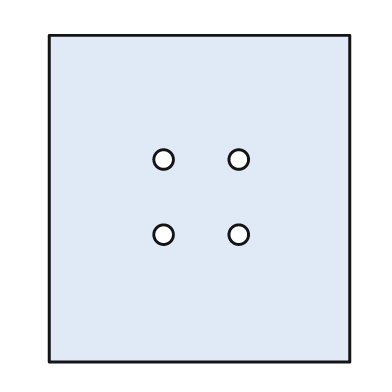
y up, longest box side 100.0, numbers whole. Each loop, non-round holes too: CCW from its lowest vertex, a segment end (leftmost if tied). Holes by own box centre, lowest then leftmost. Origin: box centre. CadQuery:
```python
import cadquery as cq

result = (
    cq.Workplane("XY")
    .moveTo(-46.0, -50.0)
    .lineTo(46.0, -50.0)
    .lineTo(46.0, 50.0)
    .lineTo(-46.0, 50.0)
    .close()
    .moveTo(-11.0, -11.0)
    .circle(3.0)
    .moveTo(12.0, -11.0)
    .circle(3.0)
    .moveTo(-11.0, 12.0)
    .circle(3.0)
    .moveTo(12.0, 12.0)
    .circle(3.0)
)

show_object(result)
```